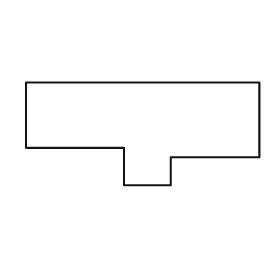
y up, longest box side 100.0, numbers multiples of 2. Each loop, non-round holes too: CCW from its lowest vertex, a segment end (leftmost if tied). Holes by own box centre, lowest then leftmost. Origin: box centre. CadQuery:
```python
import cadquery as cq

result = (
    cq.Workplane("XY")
    .moveTo(-8.0, -22.0)
    .lineTo(12.0, -22.0)
    .lineTo(12.0, -10.0)
    .lineTo(50.0, -10.0)
    .lineTo(50.0, 22.0)
    .lineTo(-50.0, 22.0)
    .lineTo(-50.0, -6.0)
    .lineTo(-8.0, -6.0)
    .close()
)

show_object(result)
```